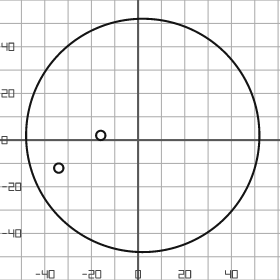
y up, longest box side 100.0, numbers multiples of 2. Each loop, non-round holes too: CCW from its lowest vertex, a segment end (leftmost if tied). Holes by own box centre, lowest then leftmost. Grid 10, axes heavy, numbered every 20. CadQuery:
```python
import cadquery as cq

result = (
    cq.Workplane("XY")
    .moveTo(2.0, 2.0)
    .circle(50.0)
    .moveTo(-34.0, -12.0)
    .circle(2.0)
    .moveTo(-16.0, 2.0)
    .circle(2.0)
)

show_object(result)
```